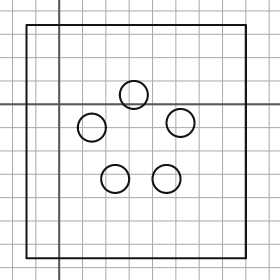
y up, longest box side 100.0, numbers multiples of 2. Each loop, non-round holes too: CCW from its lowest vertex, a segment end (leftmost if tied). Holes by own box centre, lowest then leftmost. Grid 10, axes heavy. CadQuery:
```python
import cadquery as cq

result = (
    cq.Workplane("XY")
    .moveTo(-14.0, -66.0)
    .lineTo(80.0, -66.0)
    .lineTo(80.0, 34.0)
    .lineTo(-14.0, 34.0)
    .close()
    .moveTo(24.0, -32.0)
    .circle(6.0)
    .moveTo(46.0, -32.0)
    .circle(6.0)
    .moveTo(14.0, -10.0)
    .circle(6.0)
    .moveTo(52.0, -8.0)
    .circle(6.0)
    .moveTo(32.0, 4.0)
    .circle(6.0)
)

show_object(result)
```